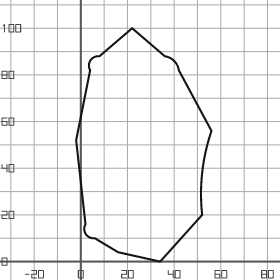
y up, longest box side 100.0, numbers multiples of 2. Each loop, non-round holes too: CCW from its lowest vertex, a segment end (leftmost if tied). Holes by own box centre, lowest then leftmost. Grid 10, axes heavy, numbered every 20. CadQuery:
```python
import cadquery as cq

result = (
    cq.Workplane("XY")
    .moveTo(34.0, 0.0)
    .lineTo(52.0, 20.0)
    .threePointArc((52.0, 38.0), (56.0, 56.0))
    .lineTo(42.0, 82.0)
    .threePointArc((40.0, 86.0), (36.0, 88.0))
    .lineTo(22.0, 100.0)
    .lineTo(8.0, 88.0)
    .threePointArc((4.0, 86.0), (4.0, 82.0))
    .lineTo(-2.0, 52.0)
    .lineTo(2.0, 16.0)
    .threePointArc((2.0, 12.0), (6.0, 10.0))
    .lineTo(16.0, 4.0)
    .close()
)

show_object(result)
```